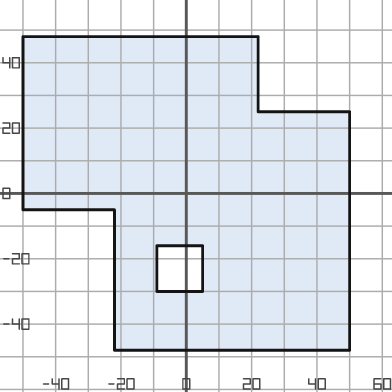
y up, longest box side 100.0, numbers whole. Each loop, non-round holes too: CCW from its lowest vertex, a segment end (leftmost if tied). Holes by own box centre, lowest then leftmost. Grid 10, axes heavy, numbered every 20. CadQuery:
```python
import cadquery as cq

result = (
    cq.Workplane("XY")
    .moveTo(-22.0, -48.0)
    .lineTo(50.0, -48.0)
    .lineTo(50.0, 25.0)
    .lineTo(22.0, 25.0)
    .lineTo(22.0, 48.0)
    .lineTo(-50.0, 48.0)
    .lineTo(-50.0, -5.0)
    .lineTo(-22.0, -5.0)
    .close()
    .moveTo(-9.0, -30.0)
    .lineTo(5.0, -30.0)
    .lineTo(5.0, -16.0)
    .lineTo(-9.0, -16.0)
    .close()
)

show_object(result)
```